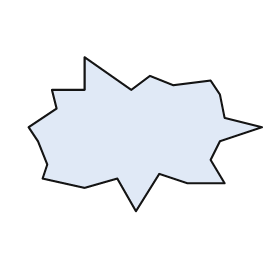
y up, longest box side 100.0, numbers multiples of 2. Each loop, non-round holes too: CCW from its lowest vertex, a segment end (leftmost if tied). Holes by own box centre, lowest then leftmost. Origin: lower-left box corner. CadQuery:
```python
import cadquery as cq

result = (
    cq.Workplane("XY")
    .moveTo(46.0, 0.0)
    .lineTo(56.0, 16.0)
    .lineTo(68.0, 12.0)
    .lineTo(84.0, 12.0)
    .lineTo(78.0, 22.0)
    .lineTo(82.0, 30.0)
    .lineTo(100.0, 36.0)
    .lineTo(84.0, 40.0)
    .lineTo(82.0, 50.0)
    .lineTo(78.0, 56.0)
    .lineTo(62.0, 54.0)
    .lineTo(52.0, 58.0)
    .lineTo(44.0, 52.0)
    .lineTo(24.0, 66.0)
    .lineTo(24.0, 52.0)
    .lineTo(10.0, 52.0)
    .lineTo(12.0, 44.0)
    .lineTo(0.0, 36.0)
    .lineTo(4.0, 30.0)
    .lineTo(8.0, 20.0)
    .lineTo(6.0, 14.0)
    .lineTo(24.0, 10.0)
    .lineTo(38.0, 14.0)
    .close()
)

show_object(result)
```